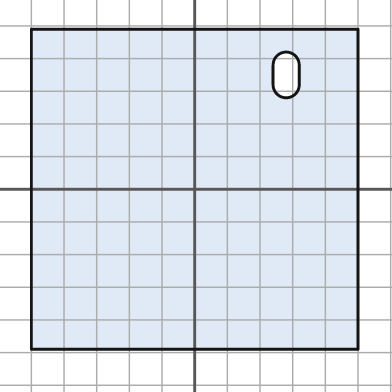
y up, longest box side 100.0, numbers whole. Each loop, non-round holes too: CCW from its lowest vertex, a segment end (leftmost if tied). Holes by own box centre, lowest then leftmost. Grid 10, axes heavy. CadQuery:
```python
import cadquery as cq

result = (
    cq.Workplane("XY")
    .moveTo(-50.0, -49.0)
    .lineTo(50.0, -49.0)
    .lineTo(50.0, 49.0)
    .lineTo(-50.0, 49.0)
    .close()
    .moveTo(24.0, 32.0)
    .threePointArc((28.0, 28.0), (32.0, 32.0))
    .lineTo(32.0, 38.0)
    .threePointArc((28.0, 42.0), (24.0, 38.0))
    .close()
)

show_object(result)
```